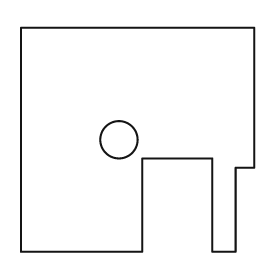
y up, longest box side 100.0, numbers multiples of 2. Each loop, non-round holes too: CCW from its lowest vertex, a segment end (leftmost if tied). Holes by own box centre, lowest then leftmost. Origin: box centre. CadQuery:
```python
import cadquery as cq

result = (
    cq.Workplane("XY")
    .moveTo(-50.0, -48.0)
    .lineTo(2.0, -48.0)
    .lineTo(2.0, -8.0)
    .lineTo(32.0, -8.0)
    .lineTo(32.0, -48.0)
    .lineTo(42.0, -48.0)
    .lineTo(42.0, -12.0)
    .lineTo(50.0, -12.0)
    .lineTo(50.0, 48.0)
    .lineTo(-50.0, 48.0)
    .close()
    .moveTo(-8.0, 0.0)
    .circle(8.0)
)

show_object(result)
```